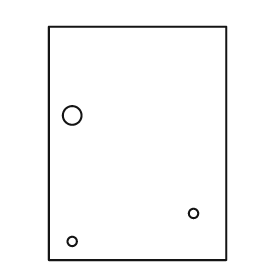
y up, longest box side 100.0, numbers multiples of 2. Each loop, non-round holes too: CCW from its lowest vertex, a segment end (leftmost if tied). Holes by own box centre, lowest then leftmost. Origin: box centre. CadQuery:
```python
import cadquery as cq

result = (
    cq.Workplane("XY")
    .moveTo(-38.0, -50.0)
    .lineTo(38.0, -50.0)
    .lineTo(38.0, 50.0)
    .lineTo(-38.0, 50.0)
    .close()
    .moveTo(-28.0, -42.0)
    .circle(2.0)
    .moveTo(24.0, -30.0)
    .circle(2.0)
    .moveTo(-28.0, 12.0)
    .circle(4.0)
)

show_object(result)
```